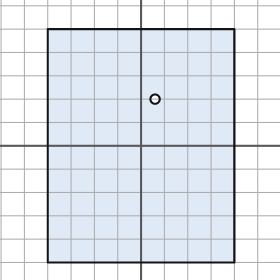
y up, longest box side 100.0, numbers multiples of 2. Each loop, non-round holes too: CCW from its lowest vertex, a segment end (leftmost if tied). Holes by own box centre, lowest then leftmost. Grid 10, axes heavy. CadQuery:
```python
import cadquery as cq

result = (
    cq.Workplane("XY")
    .moveTo(-40.0, -50.0)
    .lineTo(40.0, -50.0)
    .lineTo(40.0, 50.0)
    .lineTo(-40.0, 50.0)
    .close()
    .moveTo(6.0, 20.0)
    .circle(2.0)
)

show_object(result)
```